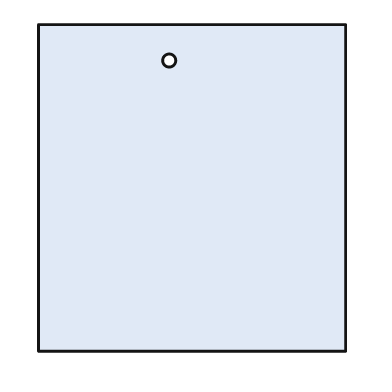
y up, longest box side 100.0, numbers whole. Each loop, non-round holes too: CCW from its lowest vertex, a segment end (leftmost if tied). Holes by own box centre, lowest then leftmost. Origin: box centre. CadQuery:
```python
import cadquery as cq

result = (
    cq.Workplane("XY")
    .moveTo(-47.0, -50.0)
    .lineTo(47.0, -50.0)
    .lineTo(47.0, 50.0)
    .lineTo(-47.0, 50.0)
    .close()
    .moveTo(-7.0, 39.0)
    .circle(2.0)
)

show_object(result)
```